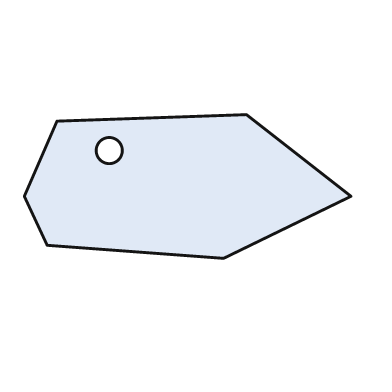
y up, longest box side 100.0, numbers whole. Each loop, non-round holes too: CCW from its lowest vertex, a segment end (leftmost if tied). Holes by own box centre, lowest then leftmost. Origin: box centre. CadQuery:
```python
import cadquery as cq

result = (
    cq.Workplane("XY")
    .moveTo(11.0, -22.0)
    .lineTo(50.0, -3.0)
    .lineTo(18.0, 22.0)
    .lineTo(-40.0, 20.0)
    .lineTo(-50.0, -3.0)
    .lineTo(-43.0, -18.0)
    .close()
    .moveTo(-24.0, 11.0)
    .circle(4.0)
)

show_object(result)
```